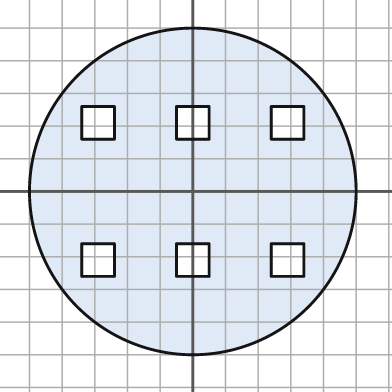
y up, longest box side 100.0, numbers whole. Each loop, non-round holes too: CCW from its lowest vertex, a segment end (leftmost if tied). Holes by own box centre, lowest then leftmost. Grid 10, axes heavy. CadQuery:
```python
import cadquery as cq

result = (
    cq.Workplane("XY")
    .moveTo(0.0, 0.0)
    .circle(50.0)
    .moveTo(-34.0, -26.0)
    .lineTo(-24.0, -26.0)
    .lineTo(-24.0, -16.0)
    .lineTo(-34.0, -16.0)
    .close()
    .moveTo(-5.0, -26.0)
    .lineTo(5.0, -26.0)
    .lineTo(5.0, -16.0)
    .lineTo(-5.0, -16.0)
    .close()
    .moveTo(24.0, -26.0)
    .lineTo(34.0, -26.0)
    .lineTo(34.0, -16.0)
    .lineTo(24.0, -16.0)
    .close()
    .moveTo(-34.0, 16.0)
    .lineTo(-24.0, 16.0)
    .lineTo(-24.0, 26.0)
    .lineTo(-34.0, 26.0)
    .close()
    .moveTo(-5.0, 16.0)
    .lineTo(5.0, 16.0)
    .lineTo(5.0, 26.0)
    .lineTo(-5.0, 26.0)
    .close()
    .moveTo(24.0, 16.0)
    .lineTo(34.0, 16.0)
    .lineTo(34.0, 26.0)
    .lineTo(24.0, 26.0)
    .close()
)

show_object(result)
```